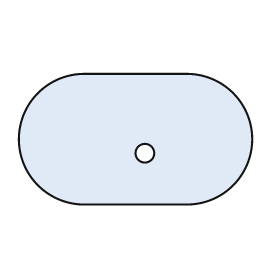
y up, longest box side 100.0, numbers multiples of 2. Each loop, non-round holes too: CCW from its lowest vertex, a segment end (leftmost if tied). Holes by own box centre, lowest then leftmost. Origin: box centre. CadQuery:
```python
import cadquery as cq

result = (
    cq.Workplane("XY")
    .moveTo(-22.0, -28.0)
    .lineTo(22.0, -28.0)
    .threePointArc((50.0, 0.0), (22.0, 28.0))
    .lineTo(-22.0, 28.0)
    .threePointArc((-50.0, 0.0), (-22.0, -28.0))
    .close()
    .moveTo(4.0, -6.0)
    .circle(4.0)
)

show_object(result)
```